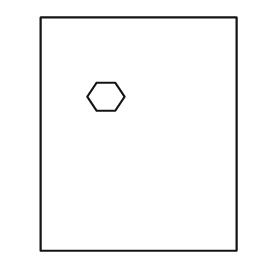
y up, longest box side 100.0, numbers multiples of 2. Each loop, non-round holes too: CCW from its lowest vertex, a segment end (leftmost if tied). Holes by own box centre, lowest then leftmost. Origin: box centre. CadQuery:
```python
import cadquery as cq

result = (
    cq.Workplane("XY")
    .moveTo(-42.0, -50.0)
    .lineTo(42.0, -50.0)
    .lineTo(42.0, 50.0)
    .lineTo(-42.0, 50.0)
    .close()
    .moveTo(-18.0, 10.0)
    .lineTo(-10.0, 10.0)
    .lineTo(-6.0, 16.0)
    .lineTo(-10.0, 22.0)
    .lineTo(-18.0, 22.0)
    .lineTo(-22.0, 16.0)
    .close()
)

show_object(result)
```